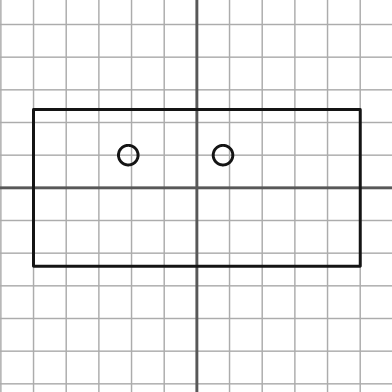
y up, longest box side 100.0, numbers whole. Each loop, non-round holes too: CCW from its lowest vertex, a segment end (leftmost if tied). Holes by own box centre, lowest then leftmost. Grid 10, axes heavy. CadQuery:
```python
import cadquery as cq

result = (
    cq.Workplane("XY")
    .moveTo(-50.0, -24.0)
    .lineTo(50.0, -24.0)
    .lineTo(50.0, 24.0)
    .lineTo(-50.0, 24.0)
    .close()
    .moveTo(-21.0, 10.0)
    .circle(3.0)
    .moveTo(8.0, 10.0)
    .circle(3.0)
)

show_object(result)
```